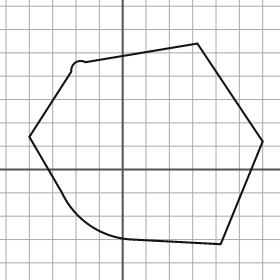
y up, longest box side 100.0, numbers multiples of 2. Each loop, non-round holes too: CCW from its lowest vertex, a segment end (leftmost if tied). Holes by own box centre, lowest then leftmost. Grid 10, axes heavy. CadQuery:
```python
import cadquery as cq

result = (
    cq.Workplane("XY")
    .moveTo(42.0, -32.0)
    .lineTo(60.0, 12.0)
    .lineTo(32.0, 54.0)
    .lineTo(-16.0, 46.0)
    .threePointArc((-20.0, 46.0), (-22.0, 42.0))
    .lineTo(-40.0, 14.0)
    .lineTo(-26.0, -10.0)
    .threePointArc((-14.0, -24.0), (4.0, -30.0))
    .close()
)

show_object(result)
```